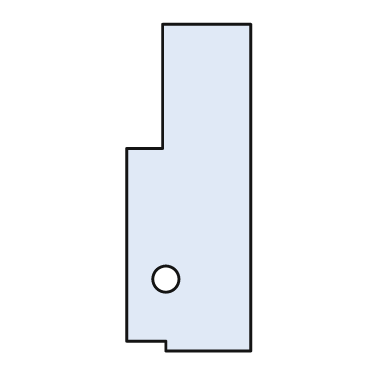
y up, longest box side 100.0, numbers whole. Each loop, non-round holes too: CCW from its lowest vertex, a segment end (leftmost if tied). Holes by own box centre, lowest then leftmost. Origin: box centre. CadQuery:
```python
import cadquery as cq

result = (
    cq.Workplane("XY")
    .moveTo(-7.0, -50.0)
    .lineTo(19.0, -50.0)
    .lineTo(19.0, 50.0)
    .lineTo(-8.0, 50.0)
    .lineTo(-8.0, 12.0)
    .lineTo(-19.0, 12.0)
    .lineTo(-19.0, -47.0)
    .lineTo(-7.0, -47.0)
    .close()
    .moveTo(-7.0, -28.0)
    .circle(4.0)
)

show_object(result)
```